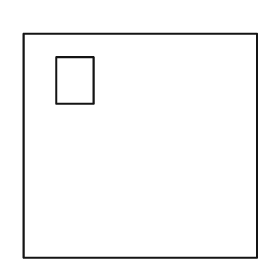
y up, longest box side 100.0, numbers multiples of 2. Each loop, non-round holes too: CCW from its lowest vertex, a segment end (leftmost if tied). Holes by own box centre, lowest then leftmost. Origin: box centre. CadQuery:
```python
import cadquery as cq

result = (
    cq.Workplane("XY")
    .moveTo(-50.0, -48.0)
    .lineTo(50.0, -48.0)
    .lineTo(50.0, 48.0)
    .lineTo(-50.0, 48.0)
    .close()
    .moveTo(-36.0, 18.0)
    .lineTo(-20.0, 18.0)
    .lineTo(-20.0, 38.0)
    .lineTo(-36.0, 38.0)
    .close()
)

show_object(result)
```